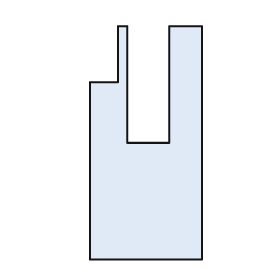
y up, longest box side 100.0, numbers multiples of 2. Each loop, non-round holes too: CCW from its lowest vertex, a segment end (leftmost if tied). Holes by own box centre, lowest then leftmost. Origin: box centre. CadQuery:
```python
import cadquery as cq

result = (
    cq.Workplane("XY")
    .moveTo(-24.0, -50.0)
    .lineTo(24.0, -50.0)
    .lineTo(24.0, 50.0)
    .lineTo(10.0, 50.0)
    .lineTo(10.0, 0.0)
    .lineTo(-8.0, 0.0)
    .lineTo(-8.0, 50.0)
    .lineTo(-12.0, 50.0)
    .lineTo(-12.0, 26.0)
    .lineTo(-24.0, 26.0)
    .close()
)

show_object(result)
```